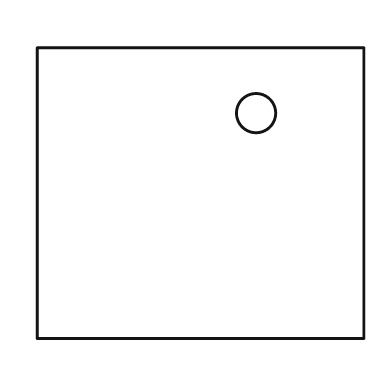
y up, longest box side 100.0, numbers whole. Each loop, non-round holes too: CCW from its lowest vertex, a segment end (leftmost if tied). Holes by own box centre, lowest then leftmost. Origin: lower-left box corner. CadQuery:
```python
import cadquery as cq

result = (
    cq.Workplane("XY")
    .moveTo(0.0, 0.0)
    .lineTo(100.0, 0.0)
    .lineTo(100.0, 89.0)
    .lineTo(0.0, 89.0)
    .close()
    .moveTo(67.0, 69.0)
    .circle(6.0)
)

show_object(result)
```